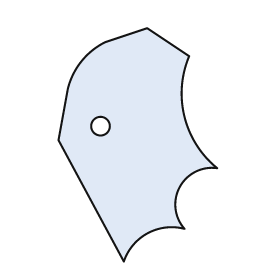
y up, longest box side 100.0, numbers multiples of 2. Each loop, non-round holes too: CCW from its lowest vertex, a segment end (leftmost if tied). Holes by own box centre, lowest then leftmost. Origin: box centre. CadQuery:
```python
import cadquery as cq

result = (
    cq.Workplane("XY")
    .moveTo(-6.0, -50.0)
    .threePointArc((4.0, -38.0), (20.0, -36.0))
    .threePointArc((18.0, -18.0), (34.0, -10.0))
    .threePointArc((20.0, 12.0), (22.0, 38.0))
    .lineTo(4.0, 50.0)
    .lineTo(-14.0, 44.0)
    .threePointArc((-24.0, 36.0), (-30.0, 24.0))
    .lineTo(-34.0, 2.0)
    .close()
    .moveTo(-16.0, 8.0)
    .circle(4.0)
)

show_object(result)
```